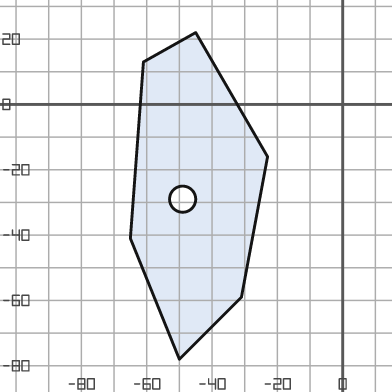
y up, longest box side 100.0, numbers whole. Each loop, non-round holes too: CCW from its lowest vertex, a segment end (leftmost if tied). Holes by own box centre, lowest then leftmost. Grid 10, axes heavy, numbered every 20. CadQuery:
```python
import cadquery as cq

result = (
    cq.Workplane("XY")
    .moveTo(-50.0, -78.0)
    .lineTo(-31.0, -59.0)
    .lineTo(-23.0, -16.0)
    .lineTo(-45.0, 22.0)
    .lineTo(-61.0, 13.0)
    .lineTo(-65.0, -41.0)
    .close()
    .moveTo(-49.0, -29.0)
    .circle(4.0)
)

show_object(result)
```